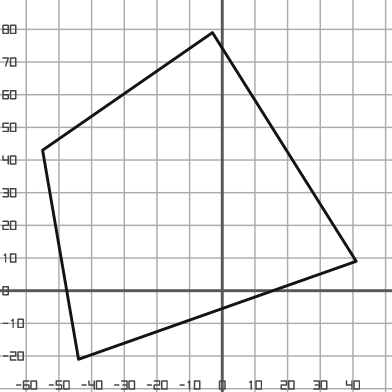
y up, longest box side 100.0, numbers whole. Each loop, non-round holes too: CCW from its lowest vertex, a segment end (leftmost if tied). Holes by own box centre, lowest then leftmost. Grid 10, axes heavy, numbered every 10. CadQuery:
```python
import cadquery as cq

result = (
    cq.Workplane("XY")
    .moveTo(-44.0, -21.0)
    .lineTo(41.0, 9.0)
    .lineTo(-3.0, 79.0)
    .lineTo(-55.0, 43.0)
    .close()
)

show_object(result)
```